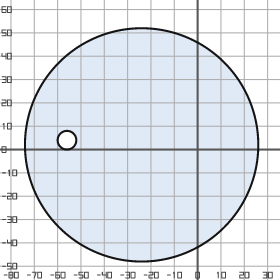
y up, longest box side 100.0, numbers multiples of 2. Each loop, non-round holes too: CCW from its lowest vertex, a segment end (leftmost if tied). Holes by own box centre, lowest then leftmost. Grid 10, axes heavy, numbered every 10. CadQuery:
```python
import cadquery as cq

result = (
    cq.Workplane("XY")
    .moveTo(-24.0, 2.0)
    .circle(50.0)
    .moveTo(-56.0, 4.0)
    .circle(4.0)
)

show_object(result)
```